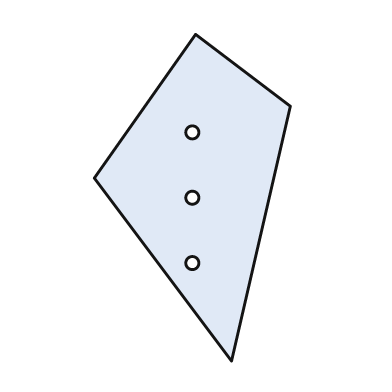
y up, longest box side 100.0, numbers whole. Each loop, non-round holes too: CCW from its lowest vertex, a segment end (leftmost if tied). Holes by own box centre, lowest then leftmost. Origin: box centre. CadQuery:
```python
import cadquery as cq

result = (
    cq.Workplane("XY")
    .moveTo(12.0, -50.0)
    .lineTo(30.0, 28.0)
    .lineTo(1.0, 50.0)
    .lineTo(-30.0, 6.0)
    .close()
    .moveTo(0.0, -20.0)
    .circle(2.0)
    .moveTo(0.0, 0.0)
    .circle(2.0)
    .moveTo(0.0, 20.0)
    .circle(2.0)
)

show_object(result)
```